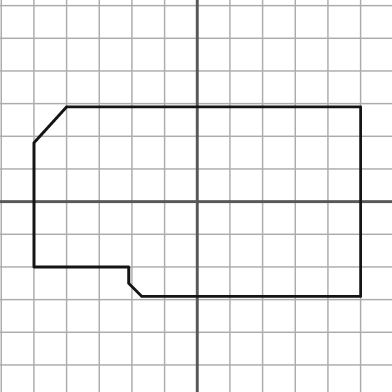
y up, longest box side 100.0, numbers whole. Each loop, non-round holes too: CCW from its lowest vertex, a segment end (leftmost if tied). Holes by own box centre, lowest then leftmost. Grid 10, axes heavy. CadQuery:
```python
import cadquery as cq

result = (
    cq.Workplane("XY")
    .moveTo(-17.0, -29.0)
    .lineTo(50.0, -29.0)
    .lineTo(50.0, 29.0)
    .lineTo(-40.0, 29.0)
    .lineTo(-50.0, 18.0)
    .lineTo(-50.0, -20.0)
    .lineTo(-21.0, -20.0)
    .lineTo(-21.0, -25.0)
    .close()
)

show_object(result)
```